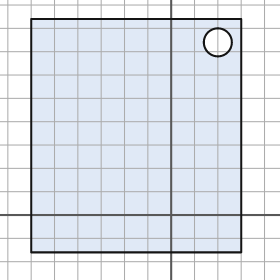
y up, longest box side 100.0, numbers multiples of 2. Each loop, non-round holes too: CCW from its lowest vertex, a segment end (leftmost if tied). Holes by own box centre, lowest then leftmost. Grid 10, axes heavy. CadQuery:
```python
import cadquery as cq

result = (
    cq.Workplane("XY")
    .moveTo(-60.0, -16.0)
    .lineTo(30.0, -16.0)
    .lineTo(30.0, 84.0)
    .lineTo(-60.0, 84.0)
    .close()
    .moveTo(20.0, 74.0)
    .circle(6.0)
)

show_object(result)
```